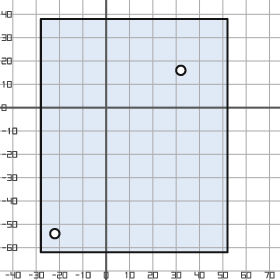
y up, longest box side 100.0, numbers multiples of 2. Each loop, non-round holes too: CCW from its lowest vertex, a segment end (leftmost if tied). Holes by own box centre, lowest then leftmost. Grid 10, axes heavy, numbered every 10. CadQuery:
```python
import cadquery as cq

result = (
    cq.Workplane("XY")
    .moveTo(-28.0, -62.0)
    .lineTo(52.0, -62.0)
    .lineTo(52.0, 38.0)
    .lineTo(-28.0, 38.0)
    .close()
    .moveTo(-22.0, -54.0)
    .circle(2.0)
    .moveTo(32.0, 16.0)
    .circle(2.0)
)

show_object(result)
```